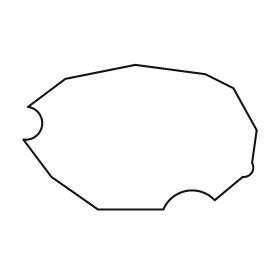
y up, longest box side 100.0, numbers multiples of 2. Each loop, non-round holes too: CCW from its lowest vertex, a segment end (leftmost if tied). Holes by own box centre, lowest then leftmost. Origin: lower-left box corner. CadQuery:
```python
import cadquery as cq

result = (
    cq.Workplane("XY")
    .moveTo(32.0, 0.0)
    .lineTo(60.0, 0.0)
    .threePointArc((70.0, 8.0), (82.0, 4.0))
    .lineTo(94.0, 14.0)
    .threePointArc((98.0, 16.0), (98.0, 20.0))
    .lineTo(100.0, 34.0)
    .lineTo(90.0, 52.0)
    .lineTo(78.0, 58.0)
    .lineTo(48.0, 62.0)
    .lineTo(18.0, 56.0)
    .lineTo(2.0, 44.0)
    .threePointArc((8.0, 36.0), (0.0, 30.0))
    .lineTo(12.0, 14.0)
    .close()
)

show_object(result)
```